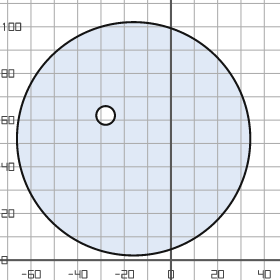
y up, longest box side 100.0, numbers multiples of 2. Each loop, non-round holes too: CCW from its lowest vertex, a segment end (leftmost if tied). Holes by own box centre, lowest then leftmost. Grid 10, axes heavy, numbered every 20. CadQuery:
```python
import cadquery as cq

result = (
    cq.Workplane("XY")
    .moveTo(-16.0, 52.0)
    .circle(50.0)
    .moveTo(-28.0, 62.0)
    .circle(4.0)
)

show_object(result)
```